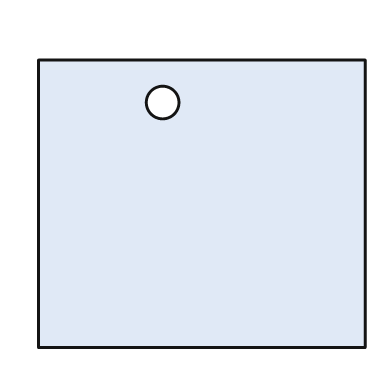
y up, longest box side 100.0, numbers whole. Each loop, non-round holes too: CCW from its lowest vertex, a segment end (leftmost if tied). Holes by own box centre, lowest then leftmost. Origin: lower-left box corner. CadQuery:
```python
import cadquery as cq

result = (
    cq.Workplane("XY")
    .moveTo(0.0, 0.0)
    .lineTo(100.0, 0.0)
    .lineTo(100.0, 88.0)
    .lineTo(0.0, 88.0)
    .close()
    .moveTo(38.0, 75.0)
    .circle(5.0)
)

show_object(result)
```